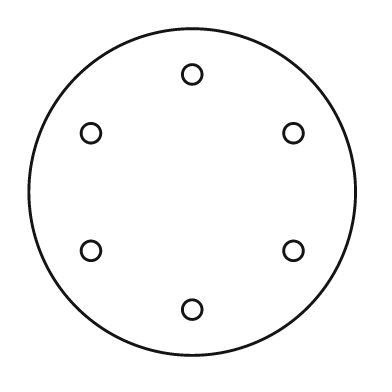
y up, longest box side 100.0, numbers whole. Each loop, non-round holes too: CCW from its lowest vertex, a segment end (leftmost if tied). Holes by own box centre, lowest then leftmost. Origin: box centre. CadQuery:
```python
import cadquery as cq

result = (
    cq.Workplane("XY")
    .moveTo(0.0, 0.0)
    .circle(50.0)
    .moveTo(0.0, -36.0)
    .circle(3.0)
    .moveTo(-31.0, -18.0)
    .circle(3.0)
    .moveTo(31.0, -18.0)
    .circle(3.0)
    .moveTo(-31.0, 18.0)
    .circle(3.0)
    .moveTo(31.0, 18.0)
    .circle(3.0)
    .moveTo(0.0, 36.0)
    .circle(3.0)
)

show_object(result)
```